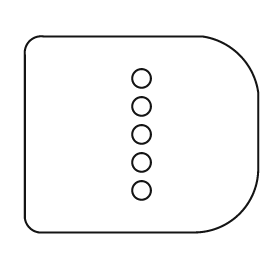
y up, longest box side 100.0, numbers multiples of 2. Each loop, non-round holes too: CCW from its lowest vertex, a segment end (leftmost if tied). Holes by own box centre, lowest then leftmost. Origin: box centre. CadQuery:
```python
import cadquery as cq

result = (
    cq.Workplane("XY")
    .moveTo(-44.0, -42.0)
    .lineTo(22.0, -42.0)
    .threePointArc((42.0, -34.0), (50.0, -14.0))
    .lineTo(50.0, 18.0)
    .threePointArc((42.0, 34.0), (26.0, 42.0))
    .lineTo(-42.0, 42.0)
    .threePointArc((-48.0, 40.0), (-50.0, 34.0))
    .lineTo(-50.0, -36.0)
    .threePointArc((-48.0, -40.0), (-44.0, -42.0))
    .close()
    .moveTo(0.0, -24.0)
    .circle(4.0)
    .moveTo(0.0, -12.0)
    .circle(4.0)
    .moveTo(0.0, 0.0)
    .circle(4.0)
    .moveTo(0.0, 12.0)
    .circle(4.0)
    .moveTo(0.0, 24.0)
    .circle(4.0)
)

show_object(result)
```